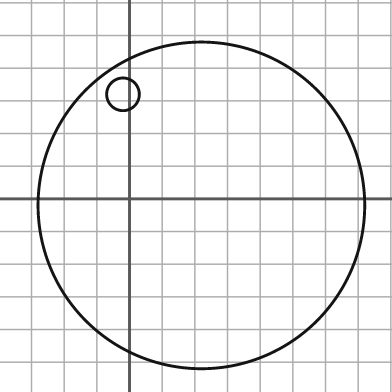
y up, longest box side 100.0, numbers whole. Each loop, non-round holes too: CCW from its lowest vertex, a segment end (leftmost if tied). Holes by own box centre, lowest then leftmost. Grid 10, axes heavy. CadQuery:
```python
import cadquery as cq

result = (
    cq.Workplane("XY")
    .moveTo(22.0, -2.0)
    .circle(50.0)
    .moveTo(-2.0, 32.0)
    .circle(5.0)
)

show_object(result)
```